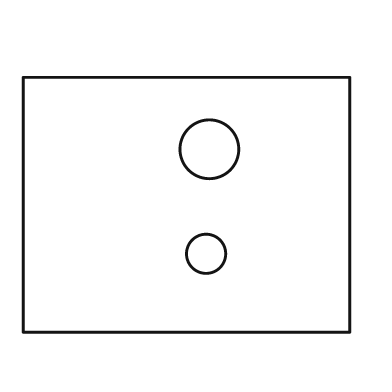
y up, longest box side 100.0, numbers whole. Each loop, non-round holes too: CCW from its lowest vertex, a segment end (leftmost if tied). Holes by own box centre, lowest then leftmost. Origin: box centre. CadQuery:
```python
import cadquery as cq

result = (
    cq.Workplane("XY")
    .moveTo(-50.0, -39.0)
    .lineTo(50.0, -39.0)
    .lineTo(50.0, 39.0)
    .lineTo(-50.0, 39.0)
    .close()
    .moveTo(6.0, -15.0)
    .circle(6.0)
    .moveTo(7.0, 17.0)
    .circle(9.0)
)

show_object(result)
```